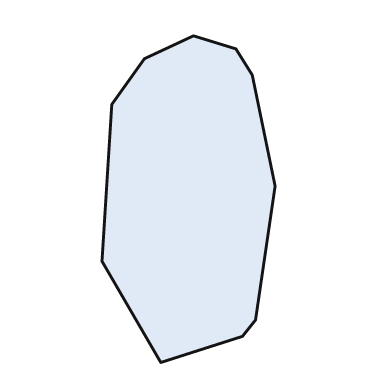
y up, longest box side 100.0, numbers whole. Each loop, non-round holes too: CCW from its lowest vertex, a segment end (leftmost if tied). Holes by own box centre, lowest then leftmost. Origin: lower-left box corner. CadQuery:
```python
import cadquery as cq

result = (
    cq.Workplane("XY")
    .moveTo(18.0, 0.0)
    .lineTo(43.0, 8.0)
    .lineTo(47.0, 13.0)
    .lineTo(53.0, 54.0)
    .lineTo(46.0, 88.0)
    .lineTo(41.0, 96.0)
    .lineTo(28.0, 100.0)
    .lineTo(13.0, 93.0)
    .lineTo(3.0, 79.0)
    .lineTo(0.0, 31.0)
    .close()
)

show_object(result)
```